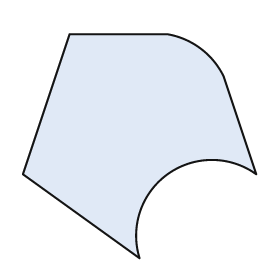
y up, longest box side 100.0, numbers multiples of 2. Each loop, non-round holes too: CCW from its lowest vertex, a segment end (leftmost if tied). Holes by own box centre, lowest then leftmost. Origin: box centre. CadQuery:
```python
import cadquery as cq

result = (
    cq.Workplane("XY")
    .moveTo(0.0, -48.0)
    .threePointArc((12.0, -12.0), (50.0, -12.0))
    .lineTo(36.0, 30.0)
    .threePointArc((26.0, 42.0), (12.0, 48.0))
    .lineTo(-30.0, 48.0)
    .lineTo(-50.0, -12.0)
    .close()
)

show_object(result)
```